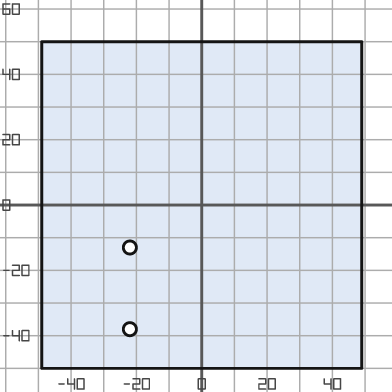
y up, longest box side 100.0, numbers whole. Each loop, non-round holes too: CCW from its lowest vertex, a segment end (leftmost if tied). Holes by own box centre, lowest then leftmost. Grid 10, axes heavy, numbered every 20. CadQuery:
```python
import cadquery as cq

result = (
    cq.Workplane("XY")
    .moveTo(-49.0, -50.0)
    .lineTo(49.0, -50.0)
    .lineTo(49.0, 50.0)
    .lineTo(-49.0, 50.0)
    .close()
    .moveTo(-22.0, -38.0)
    .circle(2.0)
    .moveTo(-22.0, -13.0)
    .circle(2.0)
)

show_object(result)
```